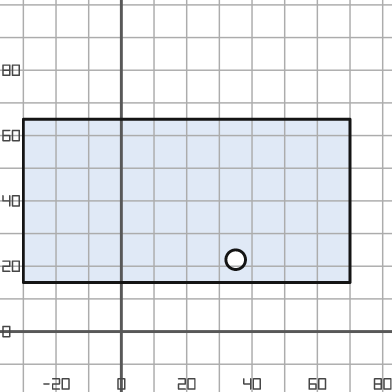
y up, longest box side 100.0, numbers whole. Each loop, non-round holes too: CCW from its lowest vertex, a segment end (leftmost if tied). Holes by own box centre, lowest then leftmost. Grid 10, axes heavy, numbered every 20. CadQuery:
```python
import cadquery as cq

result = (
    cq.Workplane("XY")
    .moveTo(-30.0, 15.0)
    .lineTo(70.0, 15.0)
    .lineTo(70.0, 65.0)
    .lineTo(-30.0, 65.0)
    .close()
    .moveTo(35.0, 22.0)
    .circle(3.0)
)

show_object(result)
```